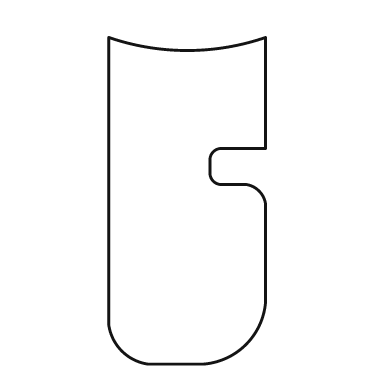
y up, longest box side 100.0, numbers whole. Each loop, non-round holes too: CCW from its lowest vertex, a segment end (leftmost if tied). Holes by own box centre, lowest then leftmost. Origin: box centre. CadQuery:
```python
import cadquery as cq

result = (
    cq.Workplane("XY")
    .moveTo(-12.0, -50.0)
    .lineTo(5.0, -50.0)
    .threePointArc((18.0, -44.0), (24.0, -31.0))
    .lineTo(24.0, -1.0)
    .threePointArc((22.0, 3.0), (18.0, 5.0))
    .lineTo(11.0, 5.0)
    .threePointArc((8.0, 6.0), (7.0, 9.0))
    .lineTo(7.0, 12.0)
    .threePointArc((8.0, 15.0), (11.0, 16.0))
    .lineTo(24.0, 16.0)
    .lineTo(24.0, 50.0)
    .threePointArc((0.0, 46.0), (-24.0, 50.0))
    .lineTo(-24.0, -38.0)
    .threePointArc((-20.0, -46.0), (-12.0, -50.0))
    .close()
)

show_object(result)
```